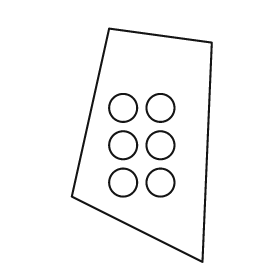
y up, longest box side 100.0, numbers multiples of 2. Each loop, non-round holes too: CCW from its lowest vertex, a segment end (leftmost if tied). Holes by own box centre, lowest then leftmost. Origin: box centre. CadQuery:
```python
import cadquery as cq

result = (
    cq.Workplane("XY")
    .moveTo(26.0, -50.0)
    .lineTo(30.0, 44.0)
    .lineTo(-14.0, 50.0)
    .lineTo(-30.0, -22.0)
    .close()
    .moveTo(-8.0, -16.0)
    .circle(6.0)
    .moveTo(8.0, -16.0)
    .circle(6.0)
    .moveTo(-8.0, 0.0)
    .circle(6.0)
    .moveTo(8.0, 0.0)
    .circle(6.0)
    .moveTo(-8.0, 16.0)
    .circle(6.0)
    .moveTo(8.0, 16.0)
    .circle(6.0)
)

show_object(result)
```